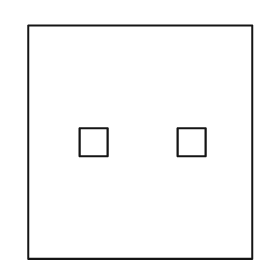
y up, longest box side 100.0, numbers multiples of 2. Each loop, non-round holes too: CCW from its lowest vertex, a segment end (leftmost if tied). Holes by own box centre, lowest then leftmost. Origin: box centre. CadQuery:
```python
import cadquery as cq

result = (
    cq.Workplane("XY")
    .moveTo(-48.0, -50.0)
    .lineTo(48.0, -50.0)
    .lineTo(48.0, 50.0)
    .lineTo(-48.0, 50.0)
    .close()
    .moveTo(-26.0, -6.0)
    .lineTo(-14.0, -6.0)
    .lineTo(-14.0, 6.0)
    .lineTo(-26.0, 6.0)
    .close()
    .moveTo(16.0, -6.0)
    .lineTo(28.0, -6.0)
    .lineTo(28.0, 6.0)
    .lineTo(16.0, 6.0)
    .close()
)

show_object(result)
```